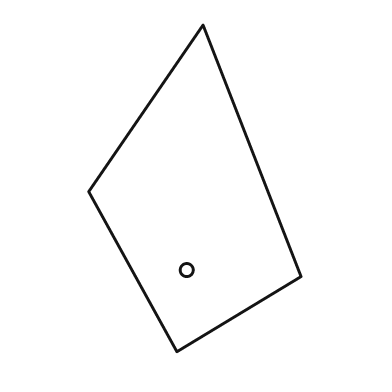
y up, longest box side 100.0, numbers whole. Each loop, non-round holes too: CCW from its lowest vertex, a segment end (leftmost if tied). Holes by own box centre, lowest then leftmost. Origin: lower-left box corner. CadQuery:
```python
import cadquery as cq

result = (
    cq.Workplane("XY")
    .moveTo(27.0, 0.0)
    .lineTo(65.0, 23.0)
    .lineTo(35.0, 100.0)
    .lineTo(0.0, 49.0)
    .close()
    .moveTo(30.0, 25.0)
    .circle(2.0)
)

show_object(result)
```